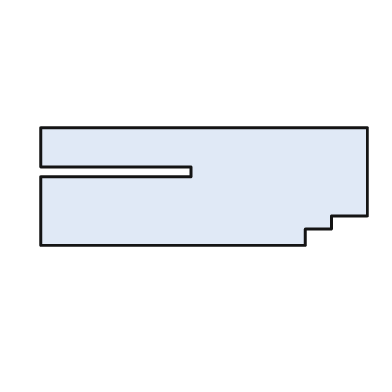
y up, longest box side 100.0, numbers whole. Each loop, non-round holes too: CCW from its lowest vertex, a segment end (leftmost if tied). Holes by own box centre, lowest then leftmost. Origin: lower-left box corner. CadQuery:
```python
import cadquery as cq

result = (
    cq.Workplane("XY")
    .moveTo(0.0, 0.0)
    .lineTo(81.0, 0.0)
    .lineTo(81.0, 5.0)
    .lineTo(89.0, 5.0)
    .lineTo(89.0, 9.0)
    .lineTo(100.0, 9.0)
    .lineTo(100.0, 36.0)
    .lineTo(0.0, 36.0)
    .lineTo(0.0, 24.0)
    .lineTo(46.0, 24.0)
    .lineTo(46.0, 21.0)
    .lineTo(0.0, 21.0)
    .close()
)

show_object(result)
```